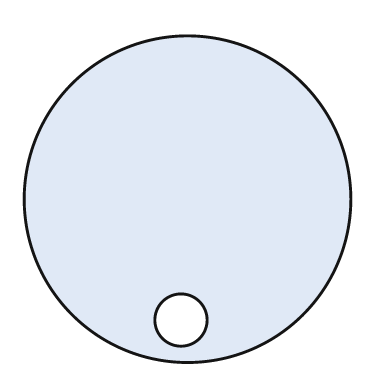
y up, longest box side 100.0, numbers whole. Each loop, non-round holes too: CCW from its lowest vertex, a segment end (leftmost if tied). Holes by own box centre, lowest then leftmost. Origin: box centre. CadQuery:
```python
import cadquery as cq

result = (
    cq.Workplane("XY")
    .moveTo(0.0, 0.0)
    .circle(50.0)
    .moveTo(-2.0, -37.0)
    .circle(8.0)
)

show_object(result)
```